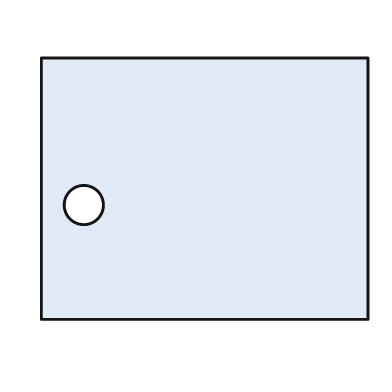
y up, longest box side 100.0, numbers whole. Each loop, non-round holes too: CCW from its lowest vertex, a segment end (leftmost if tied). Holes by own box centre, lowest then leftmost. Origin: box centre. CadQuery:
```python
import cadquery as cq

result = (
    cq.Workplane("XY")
    .moveTo(-50.0, -40.0)
    .lineTo(50.0, -40.0)
    .lineTo(50.0, 40.0)
    .lineTo(-50.0, 40.0)
    .close()
    .moveTo(-37.0, -5.0)
    .circle(6.0)
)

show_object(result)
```